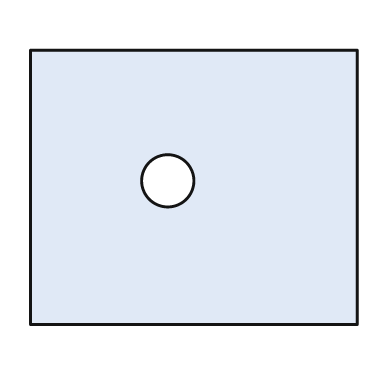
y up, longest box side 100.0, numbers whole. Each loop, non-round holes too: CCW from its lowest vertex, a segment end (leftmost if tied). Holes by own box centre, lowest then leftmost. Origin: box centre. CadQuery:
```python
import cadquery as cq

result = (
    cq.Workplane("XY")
    .moveTo(-50.0, -42.0)
    .lineTo(50.0, -42.0)
    .lineTo(50.0, 42.0)
    .lineTo(-50.0, 42.0)
    .close()
    .moveTo(-8.0, 2.0)
    .circle(8.0)
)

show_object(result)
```